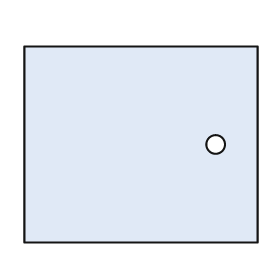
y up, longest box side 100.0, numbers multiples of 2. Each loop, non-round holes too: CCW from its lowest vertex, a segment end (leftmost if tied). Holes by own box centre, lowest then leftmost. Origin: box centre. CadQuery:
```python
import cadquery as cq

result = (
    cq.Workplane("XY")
    .moveTo(-50.0, -42.0)
    .lineTo(50.0, -42.0)
    .lineTo(50.0, 42.0)
    .lineTo(-50.0, 42.0)
    .close()
    .moveTo(32.0, 0.0)
    .circle(4.0)
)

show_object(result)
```